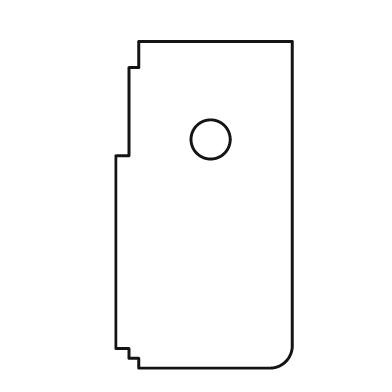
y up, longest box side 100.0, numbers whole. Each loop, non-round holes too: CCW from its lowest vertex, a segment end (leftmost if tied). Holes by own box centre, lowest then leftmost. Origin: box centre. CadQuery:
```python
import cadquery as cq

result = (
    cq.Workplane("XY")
    .moveTo(-20.0, -50.0)
    .lineTo(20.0, -50.0)
    .threePointArc((25.0, -48.0), (27.0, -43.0))
    .lineTo(27.0, 50.0)
    .lineTo(-20.0, 50.0)
    .lineTo(-20.0, 42.0)
    .lineTo(-23.0, 42.0)
    .lineTo(-23.0, 15.0)
    .lineTo(-27.0, 15.0)
    .lineTo(-27.0, -44.0)
    .lineTo(-23.0, -44.0)
    .lineTo(-23.0, -47.0)
    .lineTo(-20.0, -47.0)
    .close()
    .moveTo(2.0, 20.0)
    .circle(6.0)
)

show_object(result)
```